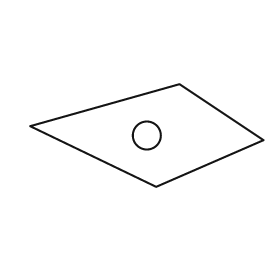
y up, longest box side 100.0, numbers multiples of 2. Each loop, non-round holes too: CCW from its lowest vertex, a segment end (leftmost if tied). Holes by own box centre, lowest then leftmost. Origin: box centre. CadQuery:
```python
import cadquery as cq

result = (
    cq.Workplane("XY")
    .moveTo(4.0, -22.0)
    .lineTo(50.0, -2.0)
    .lineTo(14.0, 22.0)
    .lineTo(-50.0, 4.0)
    .close()
    .moveTo(0.0, 0.0)
    .circle(6.0)
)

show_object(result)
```